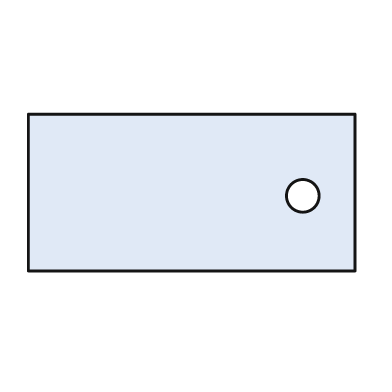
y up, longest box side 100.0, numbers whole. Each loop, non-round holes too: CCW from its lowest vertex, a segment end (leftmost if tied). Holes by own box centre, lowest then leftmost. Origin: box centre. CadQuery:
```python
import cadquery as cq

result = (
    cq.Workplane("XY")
    .moveTo(-50.0, -24.0)
    .lineTo(50.0, -24.0)
    .lineTo(50.0, 24.0)
    .lineTo(-50.0, 24.0)
    .close()
    .moveTo(34.0, -1.0)
    .circle(5.0)
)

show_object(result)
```